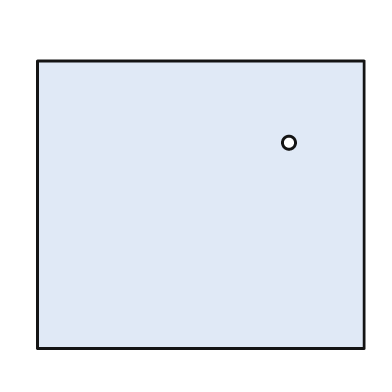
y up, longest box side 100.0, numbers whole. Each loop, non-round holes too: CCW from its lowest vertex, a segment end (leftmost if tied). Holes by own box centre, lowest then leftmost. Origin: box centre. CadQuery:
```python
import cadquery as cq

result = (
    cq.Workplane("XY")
    .moveTo(-50.0, -44.0)
    .lineTo(50.0, -44.0)
    .lineTo(50.0, 44.0)
    .lineTo(-50.0, 44.0)
    .close()
    .moveTo(27.0, 19.0)
    .circle(2.0)
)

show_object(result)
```